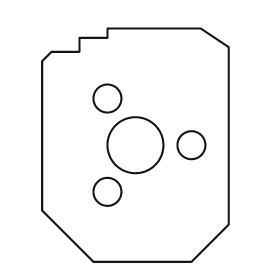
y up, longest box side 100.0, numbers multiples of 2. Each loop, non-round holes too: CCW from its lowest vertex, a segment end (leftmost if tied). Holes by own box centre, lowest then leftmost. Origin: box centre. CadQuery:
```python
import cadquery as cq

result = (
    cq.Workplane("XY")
    .moveTo(-18.0, -50.0)
    .lineTo(24.0, -50.0)
    .lineTo(40.0, -34.0)
    .lineTo(40.0, 42.0)
    .lineTo(28.0, 50.0)
    .lineTo(-12.0, 50.0)
    .lineTo(-12.0, 46.0)
    .lineTo(-24.0, 46.0)
    .lineTo(-24.0, 40.0)
    .lineTo(-36.0, 40.0)
    .lineTo(-40.0, 36.0)
    .lineTo(-40.0, -28.0)
    .close()
    .moveTo(-12.0, -20.0)
    .circle(6.0)
    .moveTo(0.0, 0.0)
    .circle(12.0)
    .moveTo(24.0, 0.0)
    .circle(6.0)
    .moveTo(-12.0, 20.0)
    .circle(6.0)
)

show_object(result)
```